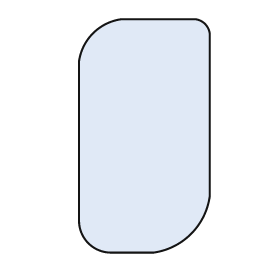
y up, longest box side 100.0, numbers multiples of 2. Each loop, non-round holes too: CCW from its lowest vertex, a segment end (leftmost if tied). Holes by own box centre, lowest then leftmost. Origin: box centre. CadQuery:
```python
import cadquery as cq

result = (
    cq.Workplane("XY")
    .moveTo(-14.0, -50.0)
    .lineTo(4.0, -50.0)
    .threePointArc((20.0, -42.0), (28.0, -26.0))
    .lineTo(28.0, 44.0)
    .threePointArc((26.0, 48.0), (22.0, 50.0))
    .lineTo(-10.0, 50.0)
    .threePointArc((-22.0, 44.0), (-28.0, 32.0))
    .lineTo(-28.0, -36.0)
    .threePointArc((-24.0, -46.0), (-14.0, -50.0))
    .close()
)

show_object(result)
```